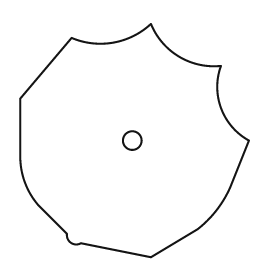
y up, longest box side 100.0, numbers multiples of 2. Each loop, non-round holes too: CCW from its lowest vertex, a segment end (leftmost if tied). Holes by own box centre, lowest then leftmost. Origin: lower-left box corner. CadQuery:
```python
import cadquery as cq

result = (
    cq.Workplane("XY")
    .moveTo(56.0, 0.0)
    .lineTo(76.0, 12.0)
    .threePointArc((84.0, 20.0), (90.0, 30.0))
    .lineTo(98.0, 50.0)
    .threePointArc((86.0, 64.0), (86.0, 82.0))
    .threePointArc((68.0, 86.0), (56.0, 100.0))
    .threePointArc((40.0, 92.0), (22.0, 94.0))
    .lineTo(0.0, 68.0)
    .lineTo(0.0, 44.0)
    .threePointArc((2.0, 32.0), (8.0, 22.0))
    .lineTo(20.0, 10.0)
    .threePointArc((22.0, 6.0), (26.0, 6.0))
    .close()
    .moveTo(48.0, 50.0)
    .circle(4.0)
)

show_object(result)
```